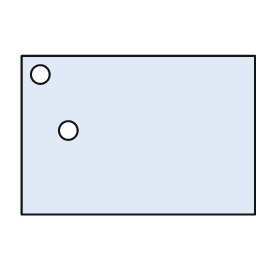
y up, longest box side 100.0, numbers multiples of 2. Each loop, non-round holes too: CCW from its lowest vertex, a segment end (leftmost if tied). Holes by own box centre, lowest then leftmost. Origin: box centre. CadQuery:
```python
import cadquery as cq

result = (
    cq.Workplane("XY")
    .moveTo(-50.0, -34.0)
    .lineTo(50.0, -34.0)
    .lineTo(50.0, 34.0)
    .lineTo(-50.0, 34.0)
    .close()
    .moveTo(-30.0, 2.0)
    .circle(4.0)
    .moveTo(-42.0, 26.0)
    .circle(4.0)
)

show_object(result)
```